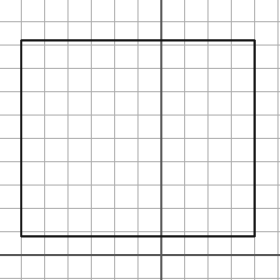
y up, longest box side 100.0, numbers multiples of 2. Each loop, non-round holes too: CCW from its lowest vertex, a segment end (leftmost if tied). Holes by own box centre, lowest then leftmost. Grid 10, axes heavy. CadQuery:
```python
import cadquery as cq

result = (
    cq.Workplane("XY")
    .moveTo(-60.0, 8.0)
    .lineTo(40.0, 8.0)
    .lineTo(40.0, 92.0)
    .lineTo(-60.0, 92.0)
    .close()
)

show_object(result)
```